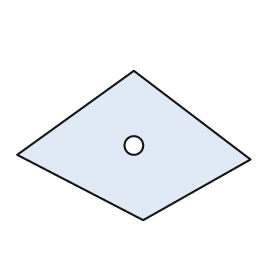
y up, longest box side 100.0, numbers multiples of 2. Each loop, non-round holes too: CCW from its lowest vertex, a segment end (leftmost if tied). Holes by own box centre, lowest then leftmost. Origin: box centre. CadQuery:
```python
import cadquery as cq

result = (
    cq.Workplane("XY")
    .moveTo(4.0, -32.0)
    .lineTo(50.0, -6.0)
    .lineTo(0.0, 32.0)
    .lineTo(-50.0, -4.0)
    .close()
    .moveTo(0.0, 0.0)
    .circle(4.0)
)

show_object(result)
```